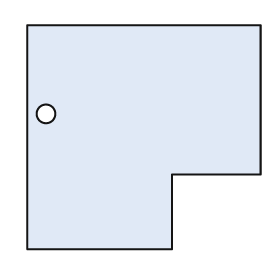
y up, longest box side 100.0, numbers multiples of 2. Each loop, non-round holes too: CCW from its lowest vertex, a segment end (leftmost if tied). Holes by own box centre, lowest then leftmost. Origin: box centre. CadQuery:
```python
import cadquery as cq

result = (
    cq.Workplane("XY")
    .moveTo(-50.0, -48.0)
    .lineTo(12.0, -48.0)
    .lineTo(12.0, -16.0)
    .lineTo(50.0, -16.0)
    .lineTo(50.0, 48.0)
    .lineTo(-50.0, 48.0)
    .close()
    .moveTo(-42.0, 10.0)
    .circle(4.0)
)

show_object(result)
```